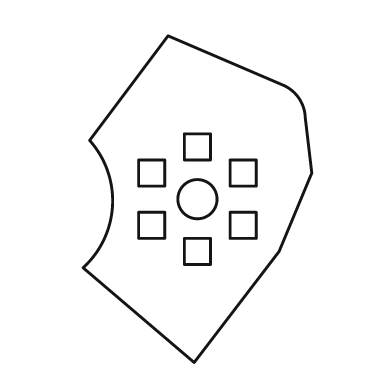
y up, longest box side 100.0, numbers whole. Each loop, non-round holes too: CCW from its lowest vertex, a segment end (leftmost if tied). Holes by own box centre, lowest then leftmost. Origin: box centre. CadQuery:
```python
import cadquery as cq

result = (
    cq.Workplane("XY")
    .moveTo(-1.0, -50.0)
    .lineTo(25.0, -16.0)
    .lineTo(35.0, 8.0)
    .lineTo(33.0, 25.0)
    .threePointArc((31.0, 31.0), (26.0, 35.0))
    .lineTo(-9.0, 50.0)
    .lineTo(-33.0, 18.0)
    .threePointArc((-26.0, -2.0), (-35.0, -21.0))
    .close()
    .moveTo(-4.0, -20.0)
    .lineTo(4.0, -20.0)
    .lineTo(4.0, -12.0)
    .lineTo(-4.0, -12.0)
    .close()
    .moveTo(-18.0, -12.0)
    .lineTo(-10.0, -12.0)
    .lineTo(-10.0, -4.0)
    .lineTo(-18.0, -4.0)
    .close()
    .moveTo(10.0, -12.0)
    .lineTo(18.0, -12.0)
    .lineTo(18.0, -4.0)
    .lineTo(10.0, -4.0)
    .close()
    .moveTo(0.0, 0.0)
    .circle(6.0)
    .moveTo(-18.0, 4.0)
    .lineTo(-10.0, 4.0)
    .lineTo(-10.0, 12.0)
    .lineTo(-18.0, 12.0)
    .close()
    .moveTo(10.0, 4.0)
    .lineTo(18.0, 4.0)
    .lineTo(18.0, 12.0)
    .lineTo(10.0, 12.0)
    .close()
    .moveTo(-4.0, 12.0)
    .lineTo(4.0, 12.0)
    .lineTo(4.0, 20.0)
    .lineTo(-4.0, 20.0)
    .close()
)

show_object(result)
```